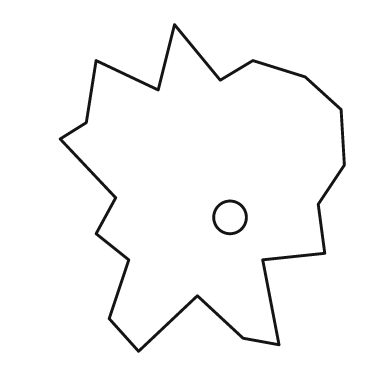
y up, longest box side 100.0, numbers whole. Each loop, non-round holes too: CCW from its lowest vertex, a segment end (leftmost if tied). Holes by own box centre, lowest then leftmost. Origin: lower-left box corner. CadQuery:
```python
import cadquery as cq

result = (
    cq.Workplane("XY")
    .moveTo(24.0, 0.0)
    .lineTo(42.0, 17.0)
    .lineTo(56.0, 4.0)
    .lineTo(67.0, 2.0)
    .lineTo(62.0, 28.0)
    .lineTo(81.0, 30.0)
    .lineTo(79.0, 45.0)
    .lineTo(87.0, 57.0)
    .lineTo(86.0, 74.0)
    .lineTo(75.0, 84.0)
    .lineTo(59.0, 89.0)
    .lineTo(49.0, 83.0)
    .lineTo(35.0, 100.0)
    .lineTo(30.0, 80.0)
    .lineTo(11.0, 89.0)
    .lineTo(8.0, 70.0)
    .lineTo(0.0, 65.0)
    .lineTo(17.0, 47.0)
    .lineTo(11.0, 36.0)
    .lineTo(21.0, 28.0)
    .lineTo(15.0, 10.0)
    .close()
    .moveTo(52.0, 41.0)
    .circle(5.0)
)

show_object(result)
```